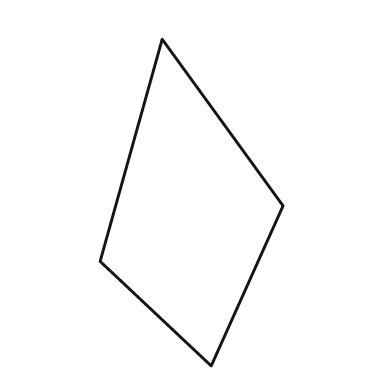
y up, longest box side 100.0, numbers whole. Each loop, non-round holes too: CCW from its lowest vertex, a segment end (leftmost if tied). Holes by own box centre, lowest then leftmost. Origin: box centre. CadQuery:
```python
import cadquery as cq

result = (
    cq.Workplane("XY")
    .moveTo(6.0, -50.0)
    .lineTo(28.0, -1.0)
    .lineTo(-9.0, 50.0)
    .lineTo(-28.0, -18.0)
    .close()
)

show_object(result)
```